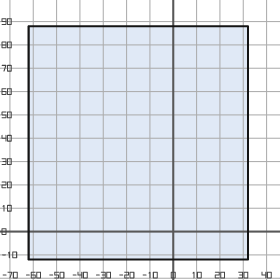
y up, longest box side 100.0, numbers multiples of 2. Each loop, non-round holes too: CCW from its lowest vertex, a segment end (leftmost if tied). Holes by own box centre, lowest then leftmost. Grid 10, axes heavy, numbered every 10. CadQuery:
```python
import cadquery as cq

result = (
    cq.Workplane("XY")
    .moveTo(-62.0, -12.0)
    .lineTo(32.0, -12.0)
    .lineTo(32.0, 88.0)
    .lineTo(-62.0, 88.0)
    .close()
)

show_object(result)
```